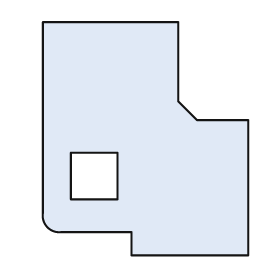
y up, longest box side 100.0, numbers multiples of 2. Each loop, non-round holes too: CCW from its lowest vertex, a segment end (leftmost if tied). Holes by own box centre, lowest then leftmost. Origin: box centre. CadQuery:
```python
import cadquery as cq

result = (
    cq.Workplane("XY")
    .moveTo(-6.0, -50.0)
    .lineTo(44.0, -50.0)
    .lineTo(44.0, 8.0)
    .lineTo(22.0, 8.0)
    .lineTo(14.0, 16.0)
    .lineTo(14.0, 50.0)
    .lineTo(-44.0, 50.0)
    .lineTo(-44.0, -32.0)
    .threePointArc((-42.0, -38.0), (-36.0, -40.0))
    .lineTo(-6.0, -40.0)
    .close()
    .moveTo(-32.0, -26.0)
    .lineTo(-12.0, -26.0)
    .lineTo(-12.0, -6.0)
    .lineTo(-32.0, -6.0)
    .close()
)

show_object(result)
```